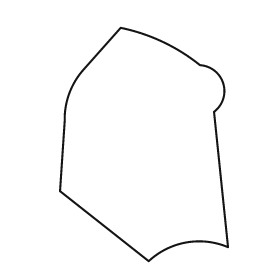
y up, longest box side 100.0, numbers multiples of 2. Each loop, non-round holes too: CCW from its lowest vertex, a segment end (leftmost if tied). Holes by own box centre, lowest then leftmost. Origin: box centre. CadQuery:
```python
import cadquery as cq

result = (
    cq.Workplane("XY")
    .moveTo(2.0, -50.0)
    .threePointArc((18.0, -42.0), (36.0, -44.0))
    .lineTo(30.0, 14.0)
    .threePointArc((34.0, 26.0), (24.0, 34.0))
    .threePointArc((8.0, 44.0), (-10.0, 50.0))
    .lineTo(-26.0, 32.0)
    .threePointArc((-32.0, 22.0), (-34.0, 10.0))
    .lineTo(-36.0, -20.0)
    .close()
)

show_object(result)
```